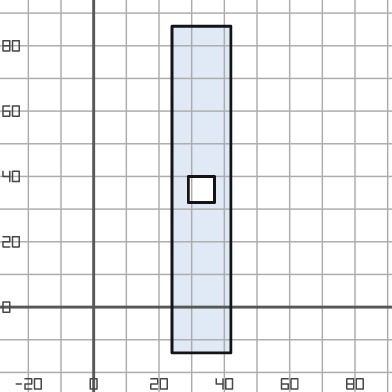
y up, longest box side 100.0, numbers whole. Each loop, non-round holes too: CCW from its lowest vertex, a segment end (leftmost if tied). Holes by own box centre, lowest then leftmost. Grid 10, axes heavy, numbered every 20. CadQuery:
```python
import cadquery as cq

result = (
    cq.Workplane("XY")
    .moveTo(24.0, -14.0)
    .lineTo(42.0, -14.0)
    .lineTo(42.0, 86.0)
    .lineTo(24.0, 86.0)
    .close()
    .moveTo(29.0, 32.0)
    .lineTo(37.0, 32.0)
    .lineTo(37.0, 40.0)
    .lineTo(29.0, 40.0)
    .close()
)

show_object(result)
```